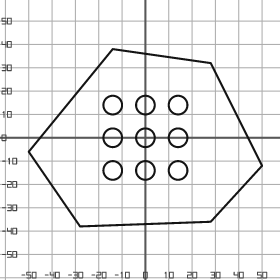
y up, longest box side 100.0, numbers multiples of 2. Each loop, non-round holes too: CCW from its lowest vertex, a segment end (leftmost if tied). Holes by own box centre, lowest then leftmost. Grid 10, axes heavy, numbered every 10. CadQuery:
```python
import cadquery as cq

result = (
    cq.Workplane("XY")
    .moveTo(-28.0, -38.0)
    .lineTo(28.0, -36.0)
    .lineTo(50.0, -12.0)
    .lineTo(28.0, 32.0)
    .lineTo(-14.0, 38.0)
    .lineTo(-50.0, -6.0)
    .close()
    .moveTo(-14.0, -14.0)
    .circle(4.0)
    .moveTo(0.0, -14.0)
    .circle(4.0)
    .moveTo(14.0, -14.0)
    .circle(4.0)
    .moveTo(-14.0, 0.0)
    .circle(4.0)
    .moveTo(0.0, 0.0)
    .circle(4.0)
    .moveTo(14.0, 0.0)
    .circle(4.0)
    .moveTo(-14.0, 14.0)
    .circle(4.0)
    .moveTo(0.0, 14.0)
    .circle(4.0)
    .moveTo(14.0, 14.0)
    .circle(4.0)
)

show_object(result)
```